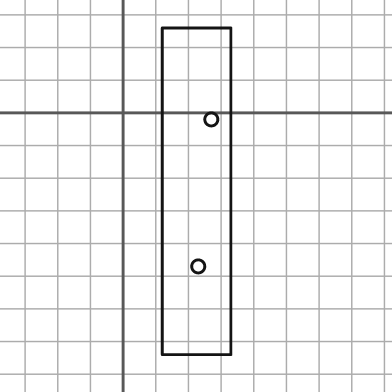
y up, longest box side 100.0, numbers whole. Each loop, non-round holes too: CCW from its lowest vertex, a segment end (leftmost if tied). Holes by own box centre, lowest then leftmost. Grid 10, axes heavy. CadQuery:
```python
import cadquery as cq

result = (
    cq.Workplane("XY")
    .moveTo(12.0, -74.0)
    .lineTo(33.0, -74.0)
    .lineTo(33.0, 26.0)
    .lineTo(12.0, 26.0)
    .close()
    .moveTo(23.0, -47.0)
    .circle(2.0)
    .moveTo(27.0, -2.0)
    .circle(2.0)
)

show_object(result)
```